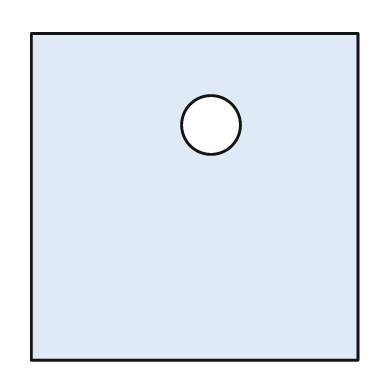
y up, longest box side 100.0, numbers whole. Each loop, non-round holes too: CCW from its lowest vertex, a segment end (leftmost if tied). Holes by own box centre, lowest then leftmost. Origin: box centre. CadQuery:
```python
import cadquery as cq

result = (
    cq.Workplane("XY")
    .moveTo(-50.0, -50.0)
    .lineTo(50.0, -50.0)
    .lineTo(50.0, 50.0)
    .lineTo(-50.0, 50.0)
    .close()
    .moveTo(5.0, 22.0)
    .circle(9.0)
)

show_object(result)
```